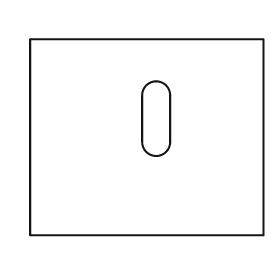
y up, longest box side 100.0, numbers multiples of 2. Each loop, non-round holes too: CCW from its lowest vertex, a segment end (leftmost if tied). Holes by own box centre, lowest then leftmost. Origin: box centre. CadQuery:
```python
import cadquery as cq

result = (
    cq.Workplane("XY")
    .moveTo(-50.0, -42.0)
    .lineTo(50.0, -42.0)
    .lineTo(50.0, 42.0)
    .lineTo(-50.0, 42.0)
    .close()
    .moveTo(-2.0, -2.0)
    .threePointArc((4.0, -8.0), (10.0, -2.0))
    .lineTo(10.0, 18.0)
    .threePointArc((4.0, 24.0), (-2.0, 18.0))
    .close()
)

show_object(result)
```